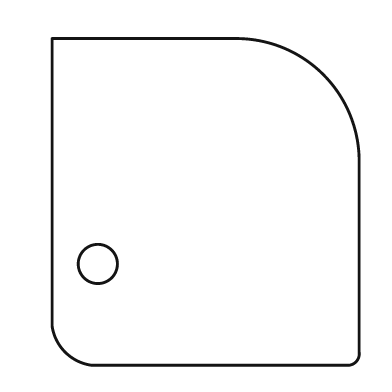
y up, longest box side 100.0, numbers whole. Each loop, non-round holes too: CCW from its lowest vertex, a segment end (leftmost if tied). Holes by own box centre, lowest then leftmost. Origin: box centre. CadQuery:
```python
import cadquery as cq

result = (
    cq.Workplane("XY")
    .moveTo(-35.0, -50.0)
    .lineTo(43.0, -50.0)
    .threePointArc((46.0, -49.0), (47.0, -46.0))
    .lineTo(47.0, 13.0)
    .threePointArc((36.0, 39.0), (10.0, 50.0))
    .lineTo(-47.0, 50.0)
    .lineTo(-47.0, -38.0)
    .threePointArc((-43.0, -46.0), (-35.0, -50.0))
    .close()
    .moveTo(-33.0, -19.0)
    .circle(6.0)
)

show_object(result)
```